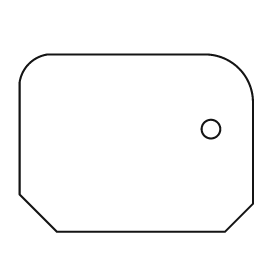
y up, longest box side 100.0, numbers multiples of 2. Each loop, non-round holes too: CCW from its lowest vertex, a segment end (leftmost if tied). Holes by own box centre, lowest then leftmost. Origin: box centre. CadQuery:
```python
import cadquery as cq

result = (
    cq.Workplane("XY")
    .moveTo(-34.0, -38.0)
    .lineTo(38.0, -38.0)
    .lineTo(50.0, -26.0)
    .lineTo(50.0, 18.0)
    .threePointArc((44.0, 32.0), (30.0, 38.0))
    .lineTo(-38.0, 38.0)
    .threePointArc((-46.0, 34.0), (-50.0, 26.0))
    .lineTo(-50.0, -22.0)
    .close()
    .moveTo(32.0, 6.0)
    .circle(4.0)
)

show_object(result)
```